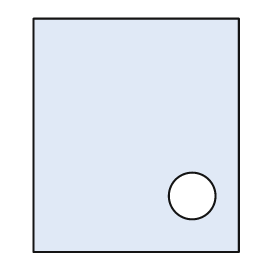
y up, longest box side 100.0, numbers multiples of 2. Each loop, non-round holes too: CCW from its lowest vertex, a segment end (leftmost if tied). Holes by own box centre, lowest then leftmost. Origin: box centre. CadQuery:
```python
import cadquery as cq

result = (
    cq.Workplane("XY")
    .moveTo(-44.0, -50.0)
    .lineTo(44.0, -50.0)
    .lineTo(44.0, 50.0)
    .lineTo(-44.0, 50.0)
    .close()
    .moveTo(24.0, -26.0)
    .circle(10.0)
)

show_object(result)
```